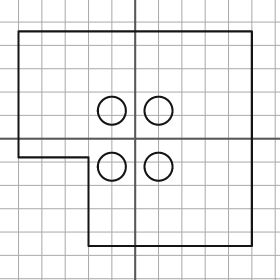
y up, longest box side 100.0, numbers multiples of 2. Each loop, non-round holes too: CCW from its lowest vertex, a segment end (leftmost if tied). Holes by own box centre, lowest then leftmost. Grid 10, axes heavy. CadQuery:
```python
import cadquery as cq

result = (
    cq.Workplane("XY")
    .moveTo(-20.0, -46.0)
    .lineTo(50.0, -46.0)
    .lineTo(50.0, 46.0)
    .lineTo(-50.0, 46.0)
    .lineTo(-50.0, -8.0)
    .lineTo(-20.0, -8.0)
    .close()
    .moveTo(-10.0, -12.0)
    .circle(6.0)
    .moveTo(10.0, -12.0)
    .circle(6.0)
    .moveTo(-10.0, 12.0)
    .circle(6.0)
    .moveTo(10.0, 12.0)
    .circle(6.0)
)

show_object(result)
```